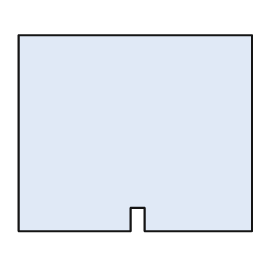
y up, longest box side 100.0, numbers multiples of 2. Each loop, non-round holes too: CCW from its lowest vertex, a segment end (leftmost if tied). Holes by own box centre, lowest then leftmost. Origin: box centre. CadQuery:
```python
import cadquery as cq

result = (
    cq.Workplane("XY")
    .moveTo(-50.0, -42.0)
    .lineTo(-2.0, -42.0)
    .lineTo(-2.0, -32.0)
    .lineTo(4.0, -32.0)
    .lineTo(4.0, -42.0)
    .lineTo(50.0, -42.0)
    .lineTo(50.0, 42.0)
    .lineTo(-50.0, 42.0)
    .close()
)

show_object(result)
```